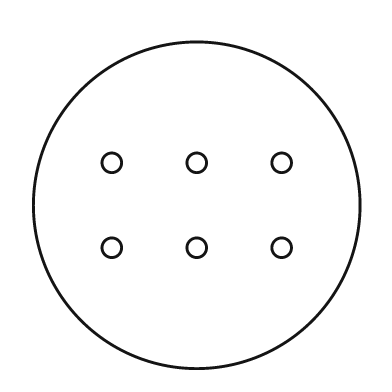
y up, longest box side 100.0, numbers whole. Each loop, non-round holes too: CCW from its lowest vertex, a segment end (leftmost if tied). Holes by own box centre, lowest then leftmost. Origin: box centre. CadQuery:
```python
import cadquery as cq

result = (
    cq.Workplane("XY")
    .moveTo(0.0, 0.0)
    .circle(50.0)
    .moveTo(-26.0, -13.0)
    .circle(3.0)
    .moveTo(0.0, -13.0)
    .circle(3.0)
    .moveTo(26.0, -13.0)
    .circle(3.0)
    .moveTo(-26.0, 13.0)
    .circle(3.0)
    .moveTo(0.0, 13.0)
    .circle(3.0)
    .moveTo(26.0, 13.0)
    .circle(3.0)
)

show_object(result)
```